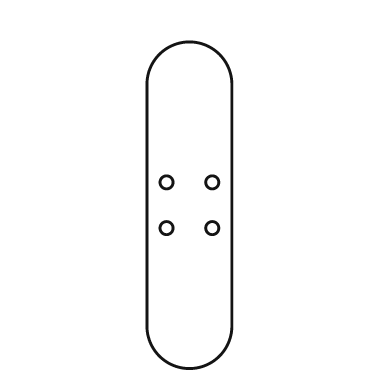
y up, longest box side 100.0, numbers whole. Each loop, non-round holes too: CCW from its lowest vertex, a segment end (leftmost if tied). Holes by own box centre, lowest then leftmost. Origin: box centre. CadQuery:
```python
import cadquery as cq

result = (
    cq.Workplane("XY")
    .moveTo(-13.0, -37.0)
    .threePointArc((0.0, -50.0), (13.0, -37.0))
    .lineTo(13.0, 37.0)
    .threePointArc((0.0, 50.0), (-13.0, 37.0))
    .close()
    .moveTo(-7.0, -7.0)
    .circle(2.0)
    .moveTo(7.0, -7.0)
    .circle(2.0)
    .moveTo(-7.0, 7.0)
    .circle(2.0)
    .moveTo(7.0, 7.0)
    .circle(2.0)
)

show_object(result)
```